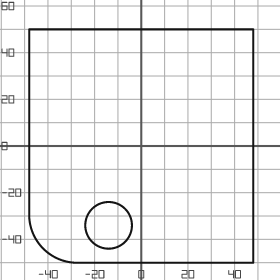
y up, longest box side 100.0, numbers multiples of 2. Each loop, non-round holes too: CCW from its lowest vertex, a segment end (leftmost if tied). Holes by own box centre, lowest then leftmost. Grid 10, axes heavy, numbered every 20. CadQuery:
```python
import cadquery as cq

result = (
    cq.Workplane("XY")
    .moveTo(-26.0, -50.0)
    .lineTo(48.0, -50.0)
    .lineTo(48.0, 50.0)
    .lineTo(-48.0, 50.0)
    .lineTo(-48.0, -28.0)
    .threePointArc((-42.0, -44.0), (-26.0, -50.0))
    .close()
    .moveTo(-14.0, -34.0)
    .circle(10.0)
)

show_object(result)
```